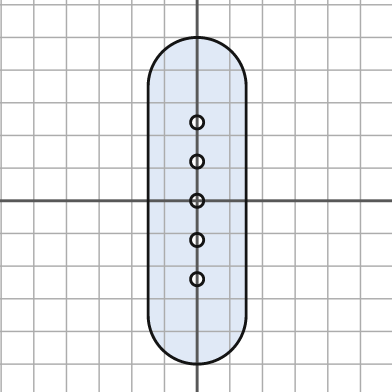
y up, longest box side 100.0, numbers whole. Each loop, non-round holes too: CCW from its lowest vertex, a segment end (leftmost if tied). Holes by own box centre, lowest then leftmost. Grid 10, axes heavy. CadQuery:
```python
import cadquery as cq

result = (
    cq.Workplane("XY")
    .moveTo(-15.0, -35.0)
    .threePointArc((0.0, -50.0), (15.0, -35.0))
    .lineTo(15.0, 35.0)
    .threePointArc((0.0, 50.0), (-15.0, 35.0))
    .close()
    .moveTo(0.0, -24.0)
    .circle(2.0)
    .moveTo(0.0, -12.0)
    .circle(2.0)
    .moveTo(0.0, 0.0)
    .circle(2.0)
    .moveTo(0.0, 12.0)
    .circle(2.0)
    .moveTo(0.0, 24.0)
    .circle(2.0)
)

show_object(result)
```